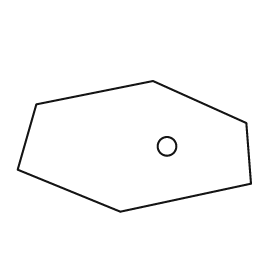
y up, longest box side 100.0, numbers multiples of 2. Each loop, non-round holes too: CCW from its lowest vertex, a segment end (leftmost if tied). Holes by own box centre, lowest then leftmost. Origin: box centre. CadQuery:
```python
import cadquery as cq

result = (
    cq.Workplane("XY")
    .moveTo(-6.0, -28.0)
    .lineTo(50.0, -16.0)
    .lineTo(48.0, 10.0)
    .lineTo(8.0, 28.0)
    .lineTo(-42.0, 18.0)
    .lineTo(-50.0, -10.0)
    .close()
    .moveTo(14.0, 0.0)
    .circle(4.0)
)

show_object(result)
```